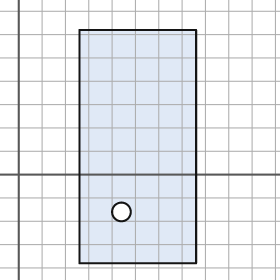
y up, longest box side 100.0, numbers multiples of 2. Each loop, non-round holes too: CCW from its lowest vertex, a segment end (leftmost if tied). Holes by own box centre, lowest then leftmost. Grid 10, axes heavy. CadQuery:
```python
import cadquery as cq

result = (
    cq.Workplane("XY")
    .moveTo(26.0, -38.0)
    .lineTo(76.0, -38.0)
    .lineTo(76.0, 62.0)
    .lineTo(26.0, 62.0)
    .close()
    .moveTo(44.0, -16.0)
    .circle(4.0)
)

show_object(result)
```